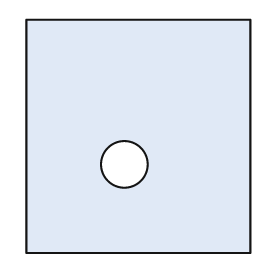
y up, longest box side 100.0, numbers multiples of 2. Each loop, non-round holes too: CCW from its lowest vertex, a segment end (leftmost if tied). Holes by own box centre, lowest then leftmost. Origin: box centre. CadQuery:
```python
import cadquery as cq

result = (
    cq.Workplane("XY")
    .moveTo(-48.0, -50.0)
    .lineTo(48.0, -50.0)
    .lineTo(48.0, 50.0)
    .lineTo(-48.0, 50.0)
    .close()
    .moveTo(-6.0, -12.0)
    .circle(10.0)
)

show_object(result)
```